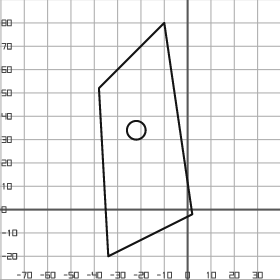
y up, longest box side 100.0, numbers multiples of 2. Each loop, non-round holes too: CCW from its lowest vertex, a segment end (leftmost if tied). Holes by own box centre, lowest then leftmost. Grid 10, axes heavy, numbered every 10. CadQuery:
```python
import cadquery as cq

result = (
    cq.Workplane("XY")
    .moveTo(-34.0, -20.0)
    .lineTo(2.0, -2.0)
    .lineTo(-10.0, 80.0)
    .lineTo(-38.0, 52.0)
    .close()
    .moveTo(-22.0, 34.0)
    .circle(4.0)
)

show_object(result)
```